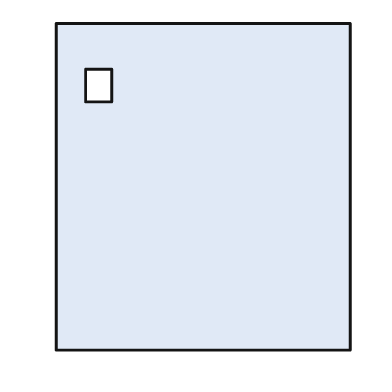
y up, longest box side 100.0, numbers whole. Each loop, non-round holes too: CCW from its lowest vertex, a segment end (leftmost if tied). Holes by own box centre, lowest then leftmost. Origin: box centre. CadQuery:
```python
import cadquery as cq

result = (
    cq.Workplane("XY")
    .moveTo(-45.0, -50.0)
    .lineTo(45.0, -50.0)
    .lineTo(45.0, 50.0)
    .lineTo(-45.0, 50.0)
    .close()
    .moveTo(-36.0, 26.0)
    .lineTo(-28.0, 26.0)
    .lineTo(-28.0, 36.0)
    .lineTo(-36.0, 36.0)
    .close()
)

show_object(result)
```